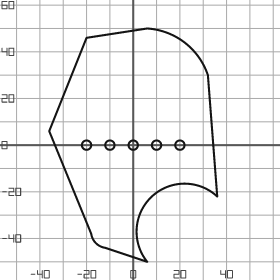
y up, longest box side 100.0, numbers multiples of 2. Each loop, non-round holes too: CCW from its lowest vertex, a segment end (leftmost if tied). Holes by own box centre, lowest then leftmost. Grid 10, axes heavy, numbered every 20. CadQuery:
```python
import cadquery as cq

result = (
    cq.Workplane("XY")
    .moveTo(6.0, -50.0)
    .threePointArc((8.0, -22.0), (36.0, -22.0))
    .lineTo(32.0, 30.0)
    .threePointArc((22.0, 44.0), (6.0, 50.0))
    .lineTo(-20.0, 46.0)
    .lineTo(-36.0, 6.0)
    .lineTo(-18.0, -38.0)
    .threePointArc((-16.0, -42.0), (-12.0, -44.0))
    .close()
    .moveTo(-20.0, 0.0)
    .circle(2.0)
    .moveTo(-10.0, 0.0)
    .circle(2.0)
    .moveTo(0.0, 0.0)
    .circle(2.0)
    .moveTo(10.0, 0.0)
    .circle(2.0)
    .moveTo(20.0, 0.0)
    .circle(2.0)
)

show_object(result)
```